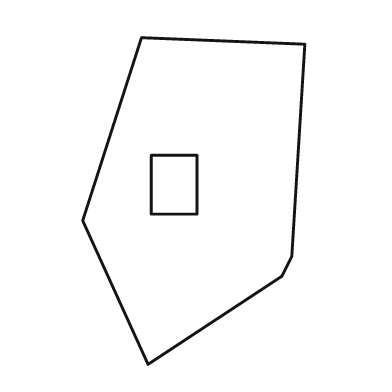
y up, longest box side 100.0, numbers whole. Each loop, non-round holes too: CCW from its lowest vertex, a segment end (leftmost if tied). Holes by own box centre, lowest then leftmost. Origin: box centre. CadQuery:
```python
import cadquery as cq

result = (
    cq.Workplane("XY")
    .moveTo(-14.0, -50.0)
    .lineTo(27.0, -23.0)
    .lineTo(30.0, -17.0)
    .lineTo(34.0, 48.0)
    .lineTo(-16.0, 50.0)
    .lineTo(-34.0, -6.0)
    .close()
    .moveTo(-13.0, -4.0)
    .lineTo(1.0, -4.0)
    .lineTo(1.0, 14.0)
    .lineTo(-13.0, 14.0)
    .close()
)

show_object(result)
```